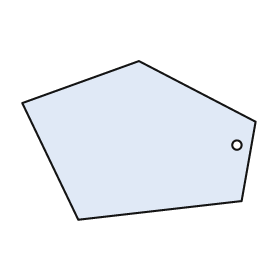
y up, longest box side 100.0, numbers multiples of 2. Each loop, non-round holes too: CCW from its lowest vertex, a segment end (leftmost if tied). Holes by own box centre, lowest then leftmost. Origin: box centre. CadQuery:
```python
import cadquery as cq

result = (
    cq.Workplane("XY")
    .moveTo(-26.0, -34.0)
    .lineTo(44.0, -26.0)
    .lineTo(50.0, 8.0)
    .lineTo(0.0, 34.0)
    .lineTo(-50.0, 16.0)
    .close()
    .moveTo(42.0, -2.0)
    .circle(2.0)
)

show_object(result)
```